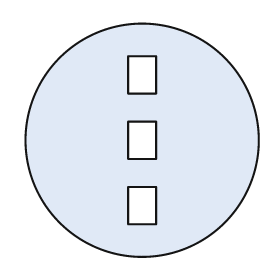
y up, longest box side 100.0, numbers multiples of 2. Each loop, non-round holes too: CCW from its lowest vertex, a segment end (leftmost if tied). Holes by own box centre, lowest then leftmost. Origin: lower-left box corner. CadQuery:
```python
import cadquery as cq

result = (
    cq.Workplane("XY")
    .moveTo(50.0, 50.0)
    .circle(50.0)
    .moveTo(44.0, 14.0)
    .lineTo(56.0, 14.0)
    .lineTo(56.0, 30.0)
    .lineTo(44.0, 30.0)
    .close()
    .moveTo(44.0, 42.0)
    .lineTo(56.0, 42.0)
    .lineTo(56.0, 58.0)
    .lineTo(44.0, 58.0)
    .close()
    .moveTo(44.0, 70.0)
    .lineTo(56.0, 70.0)
    .lineTo(56.0, 86.0)
    .lineTo(44.0, 86.0)
    .close()
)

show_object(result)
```